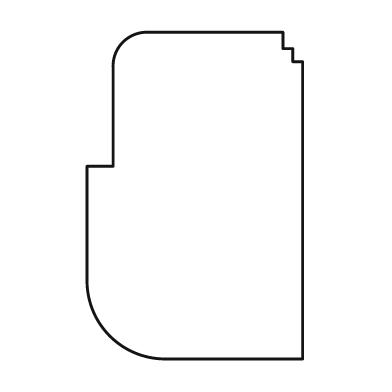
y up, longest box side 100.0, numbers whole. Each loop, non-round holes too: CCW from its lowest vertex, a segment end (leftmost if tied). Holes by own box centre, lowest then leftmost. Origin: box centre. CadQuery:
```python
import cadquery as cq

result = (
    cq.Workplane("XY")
    .moveTo(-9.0, -50.0)
    .lineTo(33.0, -50.0)
    .lineTo(33.0, 41.0)
    .lineTo(30.0, 41.0)
    .lineTo(30.0, 45.0)
    .lineTo(27.0, 45.0)
    .lineTo(27.0, 50.0)
    .lineTo(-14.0, 50.0)
    .threePointArc((-22.0, 47.0), (-25.0, 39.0))
    .lineTo(-25.0, 9.0)
    .lineTo(-33.0, 9.0)
    .lineTo(-33.0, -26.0)
    .threePointArc((-26.0, -43.0), (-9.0, -50.0))
    .close()
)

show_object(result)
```